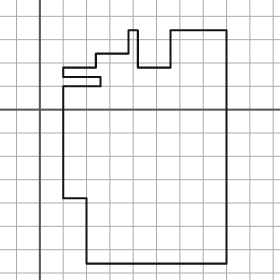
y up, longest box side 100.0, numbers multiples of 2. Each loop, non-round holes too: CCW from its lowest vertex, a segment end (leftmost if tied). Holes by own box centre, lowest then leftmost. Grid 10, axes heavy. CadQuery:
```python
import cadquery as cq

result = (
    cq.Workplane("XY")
    .moveTo(20.0, -66.0)
    .lineTo(80.0, -66.0)
    .lineTo(80.0, 34.0)
    .lineTo(56.0, 34.0)
    .lineTo(56.0, 18.0)
    .lineTo(42.0, 18.0)
    .lineTo(42.0, 34.0)
    .lineTo(38.0, 34.0)
    .lineTo(38.0, 24.0)
    .lineTo(24.0, 24.0)
    .lineTo(24.0, 18.0)
    .lineTo(10.0, 18.0)
    .lineTo(10.0, 14.0)
    .lineTo(26.0, 14.0)
    .lineTo(26.0, 10.0)
    .lineTo(10.0, 10.0)
    .lineTo(10.0, -38.0)
    .lineTo(20.0, -38.0)
    .close()
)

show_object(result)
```